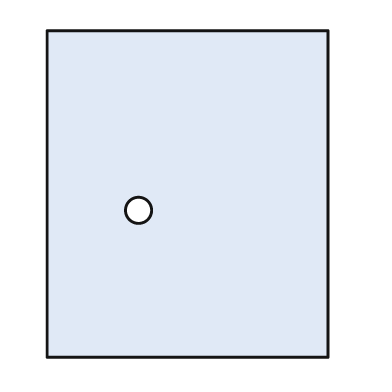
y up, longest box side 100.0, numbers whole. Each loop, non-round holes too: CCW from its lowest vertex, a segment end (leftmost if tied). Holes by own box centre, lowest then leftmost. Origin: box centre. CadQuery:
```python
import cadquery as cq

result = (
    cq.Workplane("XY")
    .moveTo(-43.0, -50.0)
    .lineTo(43.0, -50.0)
    .lineTo(43.0, 50.0)
    .lineTo(-43.0, 50.0)
    .close()
    .moveTo(-15.0, -5.0)
    .circle(4.0)
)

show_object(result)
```